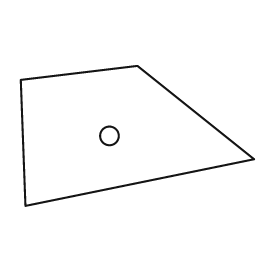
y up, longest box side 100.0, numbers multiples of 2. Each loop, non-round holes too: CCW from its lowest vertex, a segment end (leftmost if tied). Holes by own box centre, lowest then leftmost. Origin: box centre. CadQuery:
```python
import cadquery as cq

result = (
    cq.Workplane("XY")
    .moveTo(-48.0, -30.0)
    .lineTo(50.0, -10.0)
    .lineTo(0.0, 30.0)
    .lineTo(-50.0, 24.0)
    .close()
    .moveTo(-12.0, 0.0)
    .circle(4.0)
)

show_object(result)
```